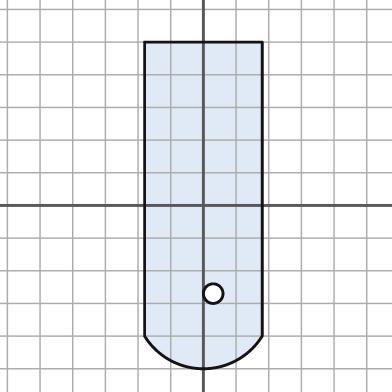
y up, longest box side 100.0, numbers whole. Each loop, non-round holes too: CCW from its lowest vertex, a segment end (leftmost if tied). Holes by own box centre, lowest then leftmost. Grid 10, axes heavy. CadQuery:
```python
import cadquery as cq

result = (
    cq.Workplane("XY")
    .moveTo(-18.0, -40.0)
    .threePointArc((0.0, -50.0), (18.0, -40.0))
    .lineTo(18.0, 50.0)
    .lineTo(-18.0, 50.0)
    .close()
    .moveTo(3.0, -27.0)
    .circle(3.0)
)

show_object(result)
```